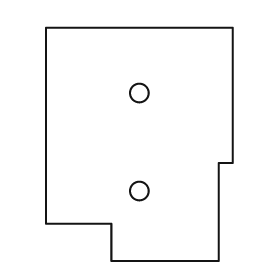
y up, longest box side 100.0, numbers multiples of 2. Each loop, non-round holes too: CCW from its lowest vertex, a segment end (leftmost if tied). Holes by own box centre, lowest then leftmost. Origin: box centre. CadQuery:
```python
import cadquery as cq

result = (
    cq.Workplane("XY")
    .moveTo(-12.0, -50.0)
    .lineTo(34.0, -50.0)
    .lineTo(34.0, -8.0)
    .lineTo(40.0, -8.0)
    .lineTo(40.0, 50.0)
    .lineTo(-40.0, 50.0)
    .lineTo(-40.0, -34.0)
    .lineTo(-12.0, -34.0)
    .close()
    .moveTo(0.0, -20.0)
    .circle(4.0)
    .moveTo(0.0, 22.0)
    .circle(4.0)
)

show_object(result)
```